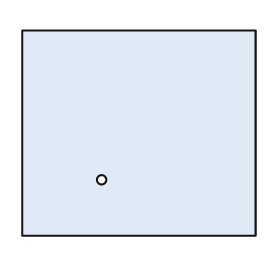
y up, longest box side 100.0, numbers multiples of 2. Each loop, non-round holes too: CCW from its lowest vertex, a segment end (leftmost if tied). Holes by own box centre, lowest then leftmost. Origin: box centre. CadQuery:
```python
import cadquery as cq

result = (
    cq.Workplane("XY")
    .moveTo(-50.0, -44.0)
    .lineTo(50.0, -44.0)
    .lineTo(50.0, 44.0)
    .lineTo(-50.0, 44.0)
    .close()
    .moveTo(-16.0, -20.0)
    .circle(2.0)
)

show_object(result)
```